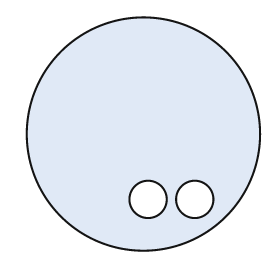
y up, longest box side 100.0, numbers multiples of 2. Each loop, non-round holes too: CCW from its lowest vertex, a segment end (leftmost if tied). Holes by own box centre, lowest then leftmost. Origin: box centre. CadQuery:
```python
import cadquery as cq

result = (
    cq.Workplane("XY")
    .moveTo(0.0, 0.0)
    .circle(50.0)
    .moveTo(2.0, -28.0)
    .circle(8.0)
    .moveTo(22.0, -28.0)
    .circle(8.0)
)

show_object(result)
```